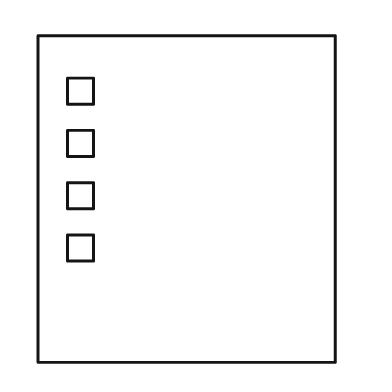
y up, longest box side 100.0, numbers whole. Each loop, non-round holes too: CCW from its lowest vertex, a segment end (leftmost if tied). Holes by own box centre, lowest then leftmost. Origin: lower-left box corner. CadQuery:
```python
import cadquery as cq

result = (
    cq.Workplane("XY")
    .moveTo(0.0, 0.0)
    .lineTo(91.0, 0.0)
    .lineTo(91.0, 100.0)
    .lineTo(0.0, 100.0)
    .close()
    .moveTo(9.0, 31.0)
    .lineTo(17.0, 31.0)
    .lineTo(17.0, 39.0)
    .lineTo(9.0, 39.0)
    .close()
    .moveTo(9.0, 47.0)
    .lineTo(17.0, 47.0)
    .lineTo(17.0, 55.0)
    .lineTo(9.0, 55.0)
    .close()
    .moveTo(9.0, 63.0)
    .lineTo(17.0, 63.0)
    .lineTo(17.0, 71.0)
    .lineTo(9.0, 71.0)
    .close()
    .moveTo(9.0, 79.0)
    .lineTo(17.0, 79.0)
    .lineTo(17.0, 87.0)
    .lineTo(9.0, 87.0)
    .close()
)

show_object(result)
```